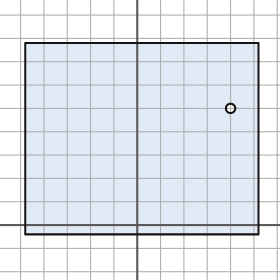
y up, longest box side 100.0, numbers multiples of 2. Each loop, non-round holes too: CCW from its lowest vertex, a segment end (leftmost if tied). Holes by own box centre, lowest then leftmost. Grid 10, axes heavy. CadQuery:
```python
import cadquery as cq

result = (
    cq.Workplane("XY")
    .moveTo(-48.0, -4.0)
    .lineTo(52.0, -4.0)
    .lineTo(52.0, 78.0)
    .lineTo(-48.0, 78.0)
    .close()
    .moveTo(40.0, 50.0)
    .circle(2.0)
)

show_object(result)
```